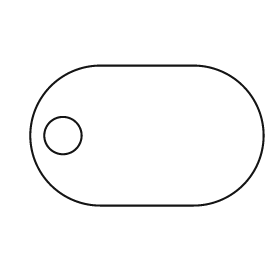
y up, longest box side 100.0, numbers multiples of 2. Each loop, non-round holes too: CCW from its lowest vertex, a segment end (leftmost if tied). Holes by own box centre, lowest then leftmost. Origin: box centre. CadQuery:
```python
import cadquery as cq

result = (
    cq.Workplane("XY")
    .moveTo(-20.0, -30.0)
    .lineTo(20.0, -30.0)
    .threePointArc((50.0, 0.0), (20.0, 30.0))
    .lineTo(-20.0, 30.0)
    .threePointArc((-50.0, 0.0), (-20.0, -30.0))
    .close()
    .moveTo(-36.0, 0.0)
    .circle(8.0)
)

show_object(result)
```